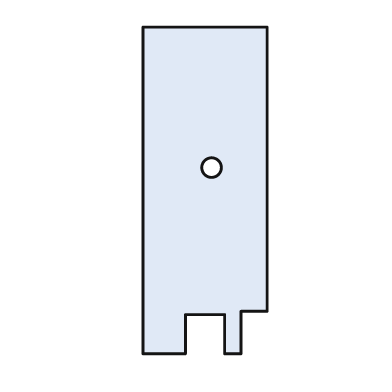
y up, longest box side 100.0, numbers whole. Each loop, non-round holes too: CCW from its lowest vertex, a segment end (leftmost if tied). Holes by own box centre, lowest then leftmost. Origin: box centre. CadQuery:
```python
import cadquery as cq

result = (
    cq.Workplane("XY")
    .moveTo(-19.0, -50.0)
    .lineTo(-6.0, -50.0)
    .lineTo(-6.0, -38.0)
    .lineTo(6.0, -38.0)
    .lineTo(6.0, -50.0)
    .lineTo(11.0, -50.0)
    .lineTo(11.0, -37.0)
    .lineTo(19.0, -37.0)
    .lineTo(19.0, 50.0)
    .lineTo(-19.0, 50.0)
    .close()
    .moveTo(2.0, 7.0)
    .circle(3.0)
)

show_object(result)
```